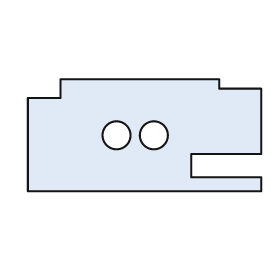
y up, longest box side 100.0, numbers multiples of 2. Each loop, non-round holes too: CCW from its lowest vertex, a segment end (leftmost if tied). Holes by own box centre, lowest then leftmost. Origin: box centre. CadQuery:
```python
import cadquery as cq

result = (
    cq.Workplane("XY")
    .moveTo(-50.0, -24.0)
    .lineTo(50.0, -24.0)
    .lineTo(50.0, -18.0)
    .lineTo(20.0, -18.0)
    .lineTo(20.0, -8.0)
    .lineTo(50.0, -8.0)
    .lineTo(50.0, 20.0)
    .lineTo(32.0, 20.0)
    .lineTo(32.0, 24.0)
    .lineTo(-36.0, 24.0)
    .lineTo(-36.0, 16.0)
    .lineTo(-50.0, 16.0)
    .close()
    .moveTo(-12.0, 0.0)
    .circle(6.0)
    .moveTo(4.0, 0.0)
    .circle(6.0)
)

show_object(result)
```